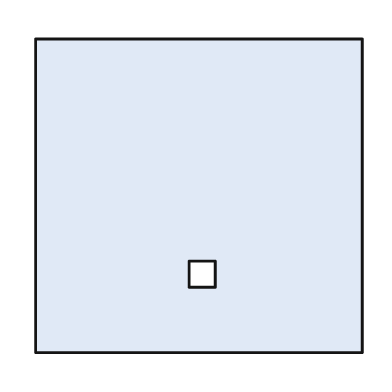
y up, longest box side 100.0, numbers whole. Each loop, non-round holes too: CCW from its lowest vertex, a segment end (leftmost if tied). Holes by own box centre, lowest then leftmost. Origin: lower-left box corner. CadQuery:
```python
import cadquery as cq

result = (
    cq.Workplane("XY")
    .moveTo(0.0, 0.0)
    .lineTo(100.0, 0.0)
    .lineTo(100.0, 96.0)
    .lineTo(0.0, 96.0)
    .close()
    .moveTo(47.0, 20.0)
    .lineTo(55.0, 20.0)
    .lineTo(55.0, 28.0)
    .lineTo(47.0, 28.0)
    .close()
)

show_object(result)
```